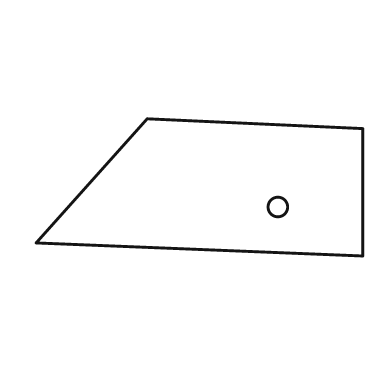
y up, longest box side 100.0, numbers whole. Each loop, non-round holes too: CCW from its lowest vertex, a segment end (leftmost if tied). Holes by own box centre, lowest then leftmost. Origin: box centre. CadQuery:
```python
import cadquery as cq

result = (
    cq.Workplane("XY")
    .moveTo(50.0, -21.0)
    .lineTo(50.0, 18.0)
    .lineTo(-16.0, 21.0)
    .lineTo(-50.0, -17.0)
    .close()
    .moveTo(24.0, -6.0)
    .circle(3.0)
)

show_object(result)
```